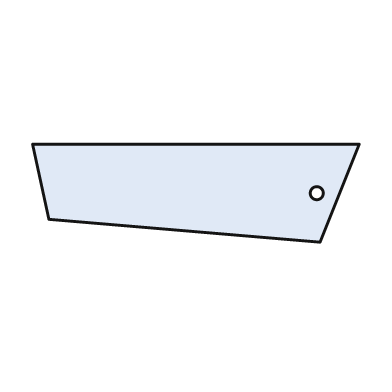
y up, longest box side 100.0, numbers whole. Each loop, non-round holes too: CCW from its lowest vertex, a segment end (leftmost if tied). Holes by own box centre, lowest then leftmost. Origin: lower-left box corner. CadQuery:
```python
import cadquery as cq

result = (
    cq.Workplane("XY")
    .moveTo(88.0, 0.0)
    .lineTo(100.0, 30.0)
    .lineTo(0.0, 30.0)
    .lineTo(5.0, 7.0)
    .close()
    .moveTo(87.0, 15.0)
    .circle(2.0)
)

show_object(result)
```